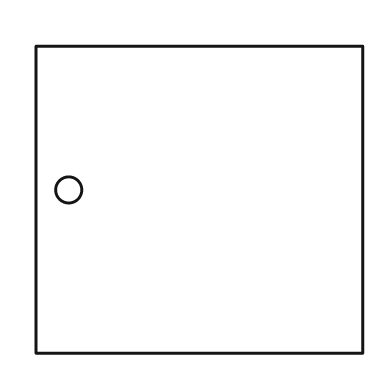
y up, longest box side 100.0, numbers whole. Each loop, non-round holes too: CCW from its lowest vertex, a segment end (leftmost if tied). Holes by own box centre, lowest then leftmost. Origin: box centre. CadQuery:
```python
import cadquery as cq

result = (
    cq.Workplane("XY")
    .moveTo(-50.0, -47.0)
    .lineTo(50.0, -47.0)
    .lineTo(50.0, 47.0)
    .lineTo(-50.0, 47.0)
    .close()
    .moveTo(-40.0, 3.0)
    .circle(4.0)
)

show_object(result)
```